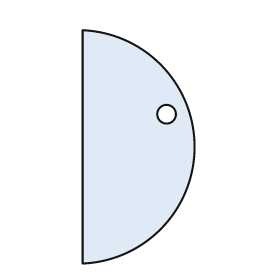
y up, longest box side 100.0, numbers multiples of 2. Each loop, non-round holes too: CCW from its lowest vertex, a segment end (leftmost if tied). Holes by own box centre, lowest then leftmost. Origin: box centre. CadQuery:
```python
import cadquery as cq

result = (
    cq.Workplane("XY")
    .moveTo(-24.0, -50.0)
    .threePointArc((24.0, 0.0), (-24.0, 50.0))
    .close()
    .moveTo(12.0, 14.0)
    .circle(4.0)
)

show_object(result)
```